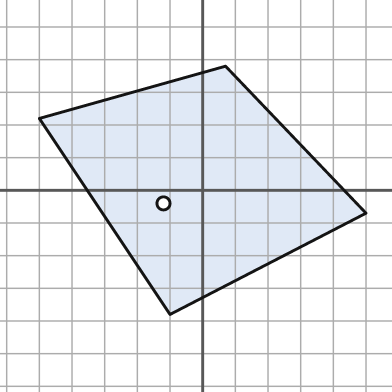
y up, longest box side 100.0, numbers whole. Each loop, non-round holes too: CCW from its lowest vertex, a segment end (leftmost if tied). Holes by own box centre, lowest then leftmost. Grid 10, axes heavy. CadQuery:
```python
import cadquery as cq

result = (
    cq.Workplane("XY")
    .moveTo(-10.0, -38.0)
    .lineTo(50.0, -7.0)
    .lineTo(7.0, 38.0)
    .lineTo(-50.0, 22.0)
    .close()
    .moveTo(-12.0, -4.0)
    .circle(2.0)
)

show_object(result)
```